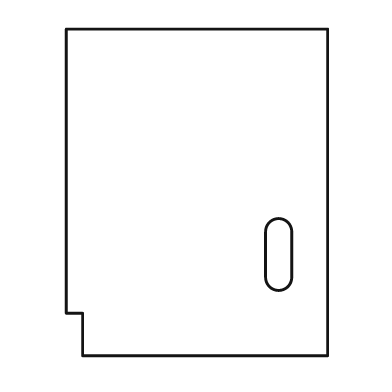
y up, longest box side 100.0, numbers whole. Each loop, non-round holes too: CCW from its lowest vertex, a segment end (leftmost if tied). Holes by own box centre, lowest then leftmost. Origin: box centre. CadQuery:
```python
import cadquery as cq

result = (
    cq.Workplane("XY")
    .moveTo(-35.0, -50.0)
    .lineTo(40.0, -50.0)
    .lineTo(40.0, 50.0)
    .lineTo(-40.0, 50.0)
    .lineTo(-40.0, -37.0)
    .lineTo(-35.0, -37.0)
    .close()
    .moveTo(21.0, -26.0)
    .threePointArc((25.0, -30.0), (29.0, -26.0))
    .lineTo(29.0, -12.0)
    .threePointArc((25.0, -8.0), (21.0, -12.0))
    .close()
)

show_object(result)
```